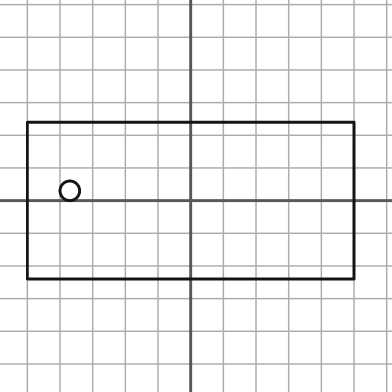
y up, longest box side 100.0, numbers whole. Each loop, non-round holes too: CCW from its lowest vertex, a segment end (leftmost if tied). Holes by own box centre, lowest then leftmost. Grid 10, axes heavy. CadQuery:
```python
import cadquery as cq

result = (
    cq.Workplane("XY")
    .moveTo(-50.0, -24.0)
    .lineTo(50.0, -24.0)
    .lineTo(50.0, 24.0)
    .lineTo(-50.0, 24.0)
    .close()
    .moveTo(-37.0, 3.0)
    .circle(3.0)
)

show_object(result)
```